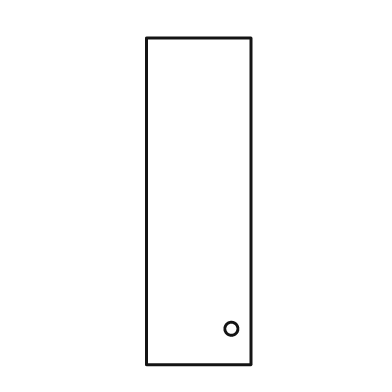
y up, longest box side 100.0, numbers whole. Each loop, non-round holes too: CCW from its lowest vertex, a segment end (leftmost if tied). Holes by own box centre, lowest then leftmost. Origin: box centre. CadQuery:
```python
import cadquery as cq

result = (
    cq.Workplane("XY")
    .moveTo(-16.0, -50.0)
    .lineTo(16.0, -50.0)
    .lineTo(16.0, 50.0)
    .lineTo(-16.0, 50.0)
    .close()
    .moveTo(10.0, -39.0)
    .circle(2.0)
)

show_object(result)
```